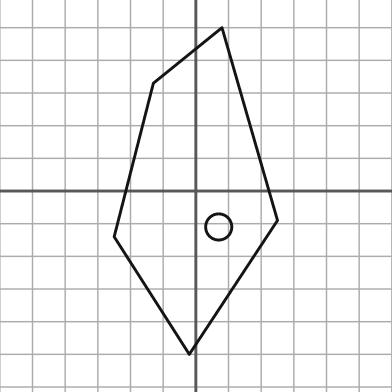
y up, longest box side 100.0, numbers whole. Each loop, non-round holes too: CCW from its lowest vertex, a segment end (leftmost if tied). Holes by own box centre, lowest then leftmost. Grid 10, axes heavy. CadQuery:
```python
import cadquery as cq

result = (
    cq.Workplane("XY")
    .moveTo(-2.0, -50.0)
    .lineTo(25.0, -9.0)
    .lineTo(8.0, 50.0)
    .lineTo(-13.0, 33.0)
    .lineTo(-25.0, -14.0)
    .close()
    .moveTo(7.0, -11.0)
    .circle(4.0)
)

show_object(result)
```